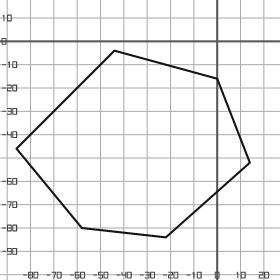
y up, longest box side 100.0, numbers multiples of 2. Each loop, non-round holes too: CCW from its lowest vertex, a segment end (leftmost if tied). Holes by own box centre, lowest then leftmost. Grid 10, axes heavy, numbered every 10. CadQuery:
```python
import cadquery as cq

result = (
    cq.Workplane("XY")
    .moveTo(-22.0, -84.0)
    .lineTo(14.0, -52.0)
    .lineTo(0.0, -16.0)
    .lineTo(-44.0, -4.0)
    .lineTo(-86.0, -46.0)
    .lineTo(-58.0, -80.0)
    .close()
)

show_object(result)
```